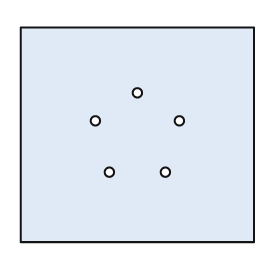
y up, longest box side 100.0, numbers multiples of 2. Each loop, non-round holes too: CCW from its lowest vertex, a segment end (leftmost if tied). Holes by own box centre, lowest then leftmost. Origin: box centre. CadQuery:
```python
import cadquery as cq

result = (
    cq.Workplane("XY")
    .moveTo(-50.0, -46.0)
    .lineTo(50.0, -46.0)
    .lineTo(50.0, 46.0)
    .lineTo(-50.0, 46.0)
    .close()
    .moveTo(-12.0, -16.0)
    .circle(2.0)
    .moveTo(12.0, -16.0)
    .circle(2.0)
    .moveTo(-18.0, 6.0)
    .circle(2.0)
    .moveTo(18.0, 6.0)
    .circle(2.0)
    .moveTo(0.0, 18.0)
    .circle(2.0)
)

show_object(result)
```